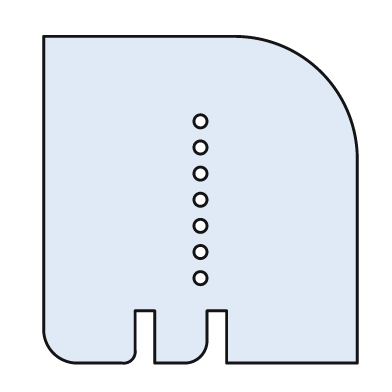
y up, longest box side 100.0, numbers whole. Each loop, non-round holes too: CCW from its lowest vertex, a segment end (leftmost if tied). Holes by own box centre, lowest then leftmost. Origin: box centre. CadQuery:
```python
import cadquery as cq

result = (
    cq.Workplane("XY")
    .moveTo(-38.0, -50.0)
    .lineTo(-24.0, -50.0)
    .threePointArc((-21.0, -49.0), (-20.0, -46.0))
    .lineTo(-20.0, -34.0)
    .lineTo(-14.0, -34.0)
    .lineTo(-14.0, -50.0)
    .lineTo(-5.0, -50.0)
    .threePointArc((0.0, -48.0), (2.0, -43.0))
    .lineTo(2.0, -34.0)
    .lineTo(8.0, -34.0)
    .lineTo(8.0, -50.0)
    .lineTo(48.0, -50.0)
    .lineTo(48.0, 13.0)
    .threePointArc((37.0, 39.0), (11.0, 50.0))
    .lineTo(-48.0, 50.0)
    .lineTo(-48.0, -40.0)
    .threePointArc((-45.0, -47.0), (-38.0, -50.0))
    .close()
    .moveTo(0.0, -24.0)
    .circle(2.0)
    .moveTo(0.0, -16.0)
    .circle(2.0)
    .moveTo(0.0, -8.0)
    .circle(2.0)
    .moveTo(0.0, 0.0)
    .circle(2.0)
    .moveTo(0.0, 8.0)
    .circle(2.0)
    .moveTo(0.0, 16.0)
    .circle(2.0)
    .moveTo(0.0, 24.0)
    .circle(2.0)
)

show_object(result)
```